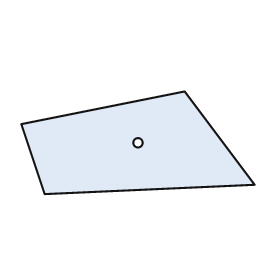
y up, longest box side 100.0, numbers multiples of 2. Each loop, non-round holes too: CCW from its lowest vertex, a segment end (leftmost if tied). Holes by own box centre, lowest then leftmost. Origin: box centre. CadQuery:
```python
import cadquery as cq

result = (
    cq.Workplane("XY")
    .moveTo(-40.0, -22.0)
    .lineTo(50.0, -18.0)
    .lineTo(20.0, 22.0)
    .lineTo(-50.0, 8.0)
    .close()
    .moveTo(0.0, 0.0)
    .circle(2.0)
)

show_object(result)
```